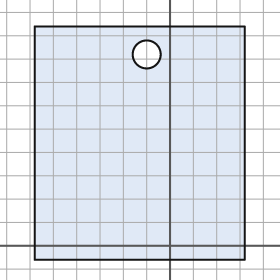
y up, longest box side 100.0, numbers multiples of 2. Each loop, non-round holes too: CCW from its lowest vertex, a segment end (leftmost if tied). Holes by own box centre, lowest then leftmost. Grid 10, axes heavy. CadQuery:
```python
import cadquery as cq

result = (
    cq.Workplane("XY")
    .moveTo(-58.0, -6.0)
    .lineTo(32.0, -6.0)
    .lineTo(32.0, 94.0)
    .lineTo(-58.0, 94.0)
    .close()
    .moveTo(-10.0, 82.0)
    .circle(6.0)
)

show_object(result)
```